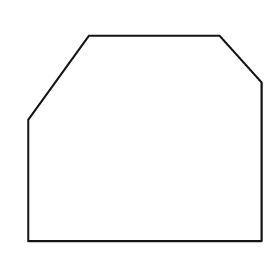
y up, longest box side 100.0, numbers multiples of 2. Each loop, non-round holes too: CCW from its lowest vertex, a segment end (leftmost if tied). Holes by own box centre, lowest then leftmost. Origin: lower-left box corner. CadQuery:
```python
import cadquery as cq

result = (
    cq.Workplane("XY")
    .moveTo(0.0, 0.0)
    .lineTo(100.0, 0.0)
    .lineTo(100.0, 68.0)
    .lineTo(82.0, 88.0)
    .lineTo(26.0, 88.0)
    .lineTo(0.0, 52.0)
    .close()
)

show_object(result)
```